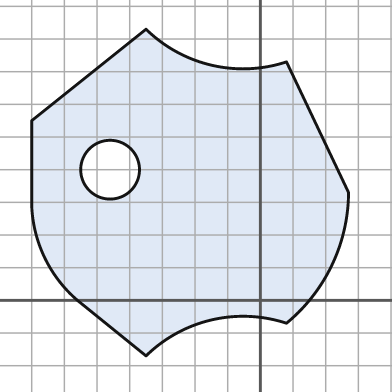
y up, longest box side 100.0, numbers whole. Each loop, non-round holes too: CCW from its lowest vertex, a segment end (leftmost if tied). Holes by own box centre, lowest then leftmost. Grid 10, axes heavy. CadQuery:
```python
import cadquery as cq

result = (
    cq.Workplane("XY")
    .moveTo(-35.0, -17.0)
    .threePointArc((-15.0, -6.0), (8.0, -7.0))
    .threePointArc((22.0, 11.0), (27.0, 33.0))
    .lineTo(8.0, 73.0)
    .threePointArc((-15.0, 72.0), (-35.0, 83.0))
    .lineTo(-70.0, 55.0)
    .lineTo(-70.0, 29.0)
    .threePointArc((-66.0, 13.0), (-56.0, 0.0))
    .close()
    .moveTo(-46.0, 40.0)
    .circle(9.0)
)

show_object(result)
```